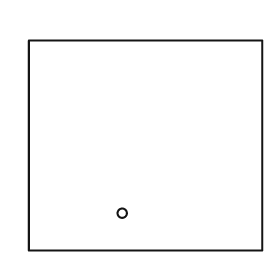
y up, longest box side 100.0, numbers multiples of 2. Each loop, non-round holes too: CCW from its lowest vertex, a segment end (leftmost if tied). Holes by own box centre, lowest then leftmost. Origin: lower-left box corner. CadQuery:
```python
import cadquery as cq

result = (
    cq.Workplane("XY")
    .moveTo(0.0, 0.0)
    .lineTo(100.0, 0.0)
    .lineTo(100.0, 90.0)
    .lineTo(0.0, 90.0)
    .close()
    .moveTo(40.0, 16.0)
    .circle(2.0)
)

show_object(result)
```